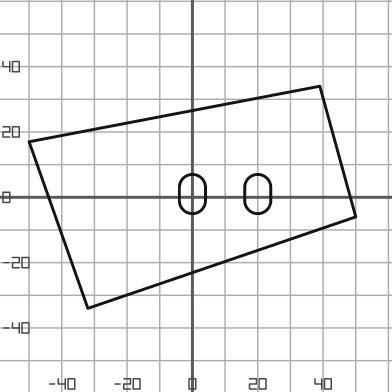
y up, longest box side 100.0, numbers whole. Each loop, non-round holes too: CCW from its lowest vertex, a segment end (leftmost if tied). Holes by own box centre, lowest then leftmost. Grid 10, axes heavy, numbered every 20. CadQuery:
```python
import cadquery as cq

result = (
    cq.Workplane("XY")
    .moveTo(-32.0, -34.0)
    .lineTo(50.0, -6.0)
    .lineTo(39.0, 34.0)
    .lineTo(-50.0, 17.0)
    .close()
    .moveTo(-4.0, -1.0)
    .threePointArc((0.0, -5.0), (4.0, -1.0))
    .lineTo(4.0, 3.0)
    .threePointArc((0.0, 7.0), (-4.0, 3.0))
    .close()
    .moveTo(16.0, -1.0)
    .threePointArc((20.0, -5.0), (24.0, -1.0))
    .lineTo(24.0, 3.0)
    .threePointArc((20.0, 7.0), (16.0, 3.0))
    .close()
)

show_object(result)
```